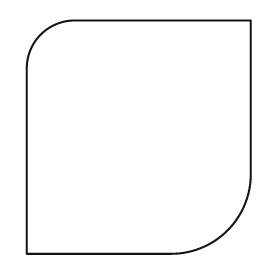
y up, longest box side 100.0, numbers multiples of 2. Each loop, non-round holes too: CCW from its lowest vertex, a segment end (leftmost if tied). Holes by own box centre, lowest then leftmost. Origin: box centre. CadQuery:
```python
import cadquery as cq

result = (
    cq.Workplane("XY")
    .moveTo(-48.0, -50.0)
    .lineTo(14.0, -50.0)
    .threePointArc((38.0, -40.0), (48.0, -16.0))
    .lineTo(48.0, 50.0)
    .lineTo(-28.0, 50.0)
    .threePointArc((-42.0, 44.0), (-48.0, 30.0))
    .close()
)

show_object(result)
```